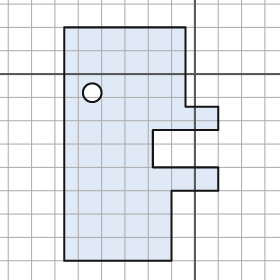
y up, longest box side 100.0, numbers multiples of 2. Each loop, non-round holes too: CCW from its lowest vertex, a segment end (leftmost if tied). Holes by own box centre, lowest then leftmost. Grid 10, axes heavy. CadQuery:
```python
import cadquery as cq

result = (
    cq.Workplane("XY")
    .moveTo(-56.0, -80.0)
    .lineTo(-10.0, -80.0)
    .lineTo(-10.0, -50.0)
    .lineTo(10.0, -50.0)
    .lineTo(10.0, -40.0)
    .lineTo(-18.0, -40.0)
    .lineTo(-18.0, -24.0)
    .lineTo(10.0, -24.0)
    .lineTo(10.0, -14.0)
    .lineTo(-4.0, -14.0)
    .lineTo(-4.0, 20.0)
    .lineTo(-56.0, 20.0)
    .close()
    .moveTo(-44.0, -8.0)
    .circle(4.0)
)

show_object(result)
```